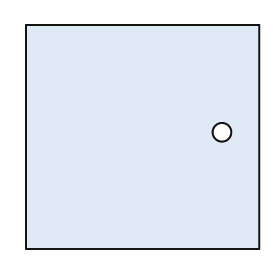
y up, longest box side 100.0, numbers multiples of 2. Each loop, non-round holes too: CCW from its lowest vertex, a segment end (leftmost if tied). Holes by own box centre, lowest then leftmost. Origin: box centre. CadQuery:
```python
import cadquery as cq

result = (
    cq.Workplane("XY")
    .moveTo(-50.0, -48.0)
    .lineTo(50.0, -48.0)
    .lineTo(50.0, 48.0)
    .lineTo(-50.0, 48.0)
    .close()
    .moveTo(34.0, 2.0)
    .circle(4.0)
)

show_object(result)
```